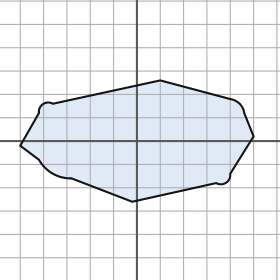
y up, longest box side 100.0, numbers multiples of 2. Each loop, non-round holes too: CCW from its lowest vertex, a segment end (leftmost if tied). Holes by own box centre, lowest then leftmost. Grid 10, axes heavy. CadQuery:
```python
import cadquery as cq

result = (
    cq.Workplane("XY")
    .moveTo(-2.0, -26.0)
    .lineTo(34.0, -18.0)
    .threePointArc((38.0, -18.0), (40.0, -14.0))
    .lineTo(50.0, 2.0)
    .lineTo(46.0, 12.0)
    .threePointArc((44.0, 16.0), (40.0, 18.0))
    .lineTo(10.0, 26.0)
    .lineTo(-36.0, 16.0)
    .threePointArc((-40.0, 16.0), (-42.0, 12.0))
    .lineTo(-50.0, -2.0)
    .lineTo(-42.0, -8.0)
    .threePointArc((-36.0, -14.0), (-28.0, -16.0))
    .close()
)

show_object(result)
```